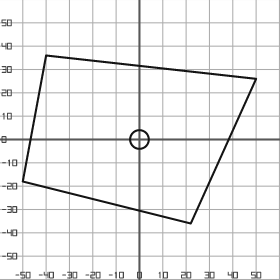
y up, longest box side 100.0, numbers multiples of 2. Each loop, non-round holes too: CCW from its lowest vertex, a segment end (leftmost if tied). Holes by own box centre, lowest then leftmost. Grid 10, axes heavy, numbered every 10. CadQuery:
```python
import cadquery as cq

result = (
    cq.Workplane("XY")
    .moveTo(22.0, -36.0)
    .lineTo(50.0, 26.0)
    .lineTo(-40.0, 36.0)
    .lineTo(-50.0, -18.0)
    .close()
    .moveTo(0.0, 0.0)
    .circle(4.0)
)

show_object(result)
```